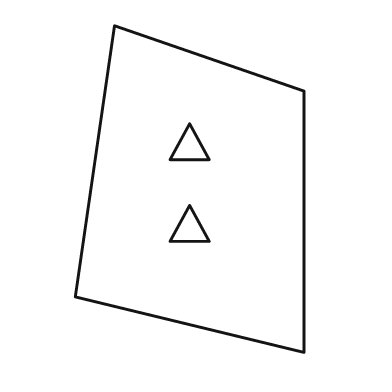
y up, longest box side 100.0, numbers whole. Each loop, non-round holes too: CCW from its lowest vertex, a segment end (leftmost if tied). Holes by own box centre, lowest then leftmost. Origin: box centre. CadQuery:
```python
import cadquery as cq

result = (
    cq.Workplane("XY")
    .moveTo(35.0, -50.0)
    .lineTo(35.0, 30.0)
    .lineTo(-23.0, 50.0)
    .lineTo(-35.0, -33.0)
    .close()
    .moveTo(-6.0, -16.0)
    .lineTo(6.0, -16.0)
    .lineTo(0.0, -5.0)
    .close()
    .moveTo(-6.0, 9.0)
    .lineTo(6.0, 9.0)
    .lineTo(0.0, 20.0)
    .close()
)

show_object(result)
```